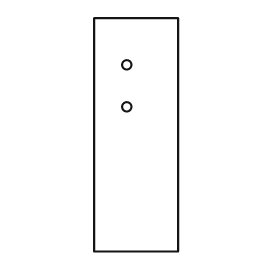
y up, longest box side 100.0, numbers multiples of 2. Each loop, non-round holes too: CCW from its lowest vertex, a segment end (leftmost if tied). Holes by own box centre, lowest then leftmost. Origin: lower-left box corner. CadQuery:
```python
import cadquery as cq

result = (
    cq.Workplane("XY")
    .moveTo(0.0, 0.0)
    .lineTo(36.0, 0.0)
    .lineTo(36.0, 100.0)
    .lineTo(0.0, 100.0)
    .close()
    .moveTo(14.0, 62.0)
    .circle(2.0)
    .moveTo(14.0, 80.0)
    .circle(2.0)
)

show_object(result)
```